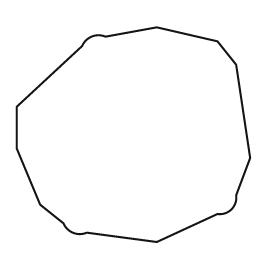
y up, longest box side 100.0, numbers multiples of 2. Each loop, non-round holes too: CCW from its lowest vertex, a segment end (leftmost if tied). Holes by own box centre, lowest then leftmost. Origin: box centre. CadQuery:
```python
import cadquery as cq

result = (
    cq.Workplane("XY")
    .moveTo(10.0, -46.0)
    .lineTo(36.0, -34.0)
    .threePointArc((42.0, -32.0), (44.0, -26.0))
    .lineTo(50.0, -10.0)
    .lineTo(44.0, 30.0)
    .lineTo(36.0, 40.0)
    .lineTo(10.0, 46.0)
    .lineTo(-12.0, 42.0)
    .threePointArc((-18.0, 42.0), (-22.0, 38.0))
    .lineTo(-50.0, 12.0)
    .lineTo(-50.0, -6.0)
    .lineTo(-40.0, -30.0)
    .lineTo(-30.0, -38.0)
    .threePointArc((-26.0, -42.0), (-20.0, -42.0))
    .close()
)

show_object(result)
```